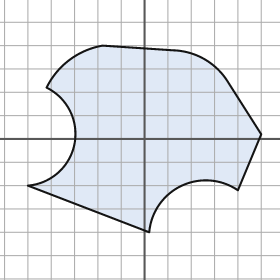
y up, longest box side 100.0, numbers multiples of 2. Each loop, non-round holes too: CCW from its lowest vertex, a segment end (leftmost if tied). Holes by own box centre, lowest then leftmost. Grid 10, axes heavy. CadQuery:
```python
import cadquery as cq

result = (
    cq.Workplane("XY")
    .moveTo(2.0, -40.0)
    .threePointArc((16.0, -20.0), (40.0, -22.0))
    .lineTo(50.0, 2.0)
    .lineTo(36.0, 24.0)
    .threePointArc((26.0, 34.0), (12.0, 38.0))
    .lineTo(-18.0, 40.0)
    .threePointArc((-32.0, 34.0), (-42.0, 22.0))
    .threePointArc((-30.0, -2.0), (-50.0, -20.0))
    .close()
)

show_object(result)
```